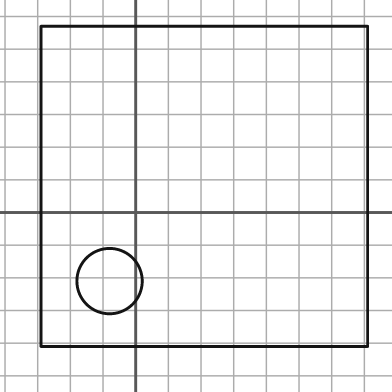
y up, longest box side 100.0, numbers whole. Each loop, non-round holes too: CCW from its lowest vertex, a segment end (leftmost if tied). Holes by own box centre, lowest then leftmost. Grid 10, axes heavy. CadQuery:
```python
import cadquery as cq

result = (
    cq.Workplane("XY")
    .moveTo(-29.0, -41.0)
    .lineTo(71.0, -41.0)
    .lineTo(71.0, 57.0)
    .lineTo(-29.0, 57.0)
    .close()
    .moveTo(-8.0, -21.0)
    .circle(10.0)
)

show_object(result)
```